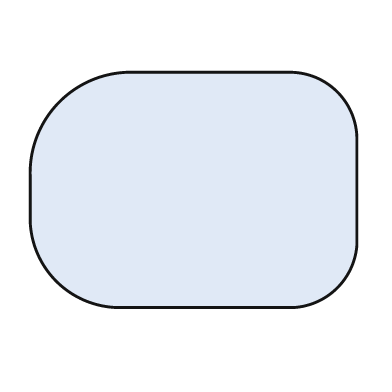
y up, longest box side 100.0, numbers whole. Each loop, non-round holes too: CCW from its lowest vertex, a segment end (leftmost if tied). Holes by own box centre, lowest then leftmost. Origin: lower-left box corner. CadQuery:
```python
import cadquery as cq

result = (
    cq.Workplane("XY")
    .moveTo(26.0, 0.0)
    .lineTo(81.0, 0.0)
    .threePointArc((94.0, 6.0), (100.0, 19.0))
    .lineTo(100.0, 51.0)
    .threePointArc((94.0, 66.0), (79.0, 72.0))
    .lineTo(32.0, 72.0)
    .threePointArc((9.0, 63.0), (0.0, 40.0))
    .lineTo(0.0, 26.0)
    .threePointArc((8.0, 8.0), (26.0, 0.0))
    .close()
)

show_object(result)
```